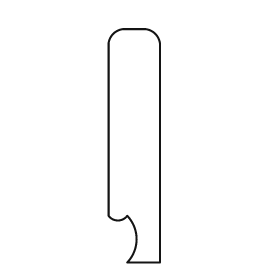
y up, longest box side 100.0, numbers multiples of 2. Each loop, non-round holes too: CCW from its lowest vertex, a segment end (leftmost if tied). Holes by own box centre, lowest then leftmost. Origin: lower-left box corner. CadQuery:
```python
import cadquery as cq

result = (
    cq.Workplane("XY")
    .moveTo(8.0, 0.0)
    .lineTo(22.0, 0.0)
    .lineTo(22.0, 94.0)
    .threePointArc((20.0, 98.0), (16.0, 100.0))
    .lineTo(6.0, 100.0)
    .threePointArc((2.0, 98.0), (0.0, 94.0))
    .lineTo(0.0, 20.0)
    .threePointArc((4.0, 18.0), (8.0, 20.0))
    .threePointArc((12.0, 10.0), (8.0, 0.0))
    .close()
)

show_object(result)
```